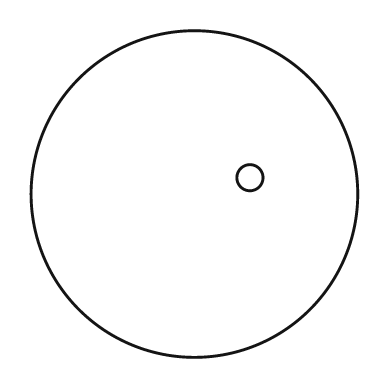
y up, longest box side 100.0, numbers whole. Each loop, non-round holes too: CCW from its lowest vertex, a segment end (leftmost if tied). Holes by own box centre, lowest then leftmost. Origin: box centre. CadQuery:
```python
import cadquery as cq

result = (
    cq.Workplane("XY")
    .moveTo(0.0, 0.0)
    .circle(50.0)
    .moveTo(17.0, 5.0)
    .circle(4.0)
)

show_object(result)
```